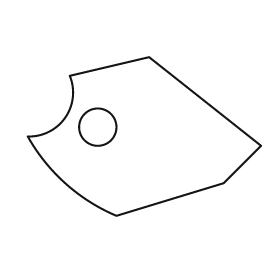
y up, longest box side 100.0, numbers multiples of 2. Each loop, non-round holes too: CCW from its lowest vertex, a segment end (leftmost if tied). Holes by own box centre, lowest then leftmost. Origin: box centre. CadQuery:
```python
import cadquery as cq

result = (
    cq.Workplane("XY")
    .moveTo(-12.0, -34.0)
    .lineTo(34.0, -20.0)
    .lineTo(50.0, -4.0)
    .lineTo(2.0, 34.0)
    .lineTo(-32.0, 26.0)
    .threePointArc((-34.0, 8.0), (-50.0, 0.0))
    .threePointArc((-34.0, -20.0), (-12.0, -34.0))
    .close()
    .moveTo(-20.0, 4.0)
    .circle(8.0)
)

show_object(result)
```